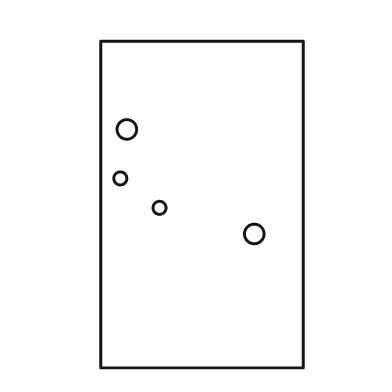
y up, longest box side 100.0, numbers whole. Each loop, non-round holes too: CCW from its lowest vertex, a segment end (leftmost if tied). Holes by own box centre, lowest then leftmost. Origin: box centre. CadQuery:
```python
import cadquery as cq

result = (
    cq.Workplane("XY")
    .moveTo(-31.0, -50.0)
    .lineTo(31.0, -50.0)
    .lineTo(31.0, 50.0)
    .lineTo(-31.0, 50.0)
    .close()
    .moveTo(16.0, -9.0)
    .circle(3.0)
    .moveTo(-13.0, -1.0)
    .circle(2.0)
    .moveTo(-25.0, 8.0)
    .circle(2.0)
    .moveTo(-23.0, 23.0)
    .circle(3.0)
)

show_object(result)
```